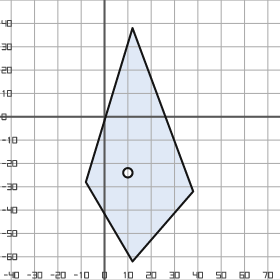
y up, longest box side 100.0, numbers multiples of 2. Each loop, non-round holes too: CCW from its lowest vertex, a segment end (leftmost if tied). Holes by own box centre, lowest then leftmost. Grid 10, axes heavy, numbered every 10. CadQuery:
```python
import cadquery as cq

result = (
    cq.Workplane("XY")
    .moveTo(12.0, -62.0)
    .lineTo(38.0, -32.0)
    .lineTo(12.0, 38.0)
    .lineTo(-8.0, -28.0)
    .close()
    .moveTo(10.0, -24.0)
    .circle(2.0)
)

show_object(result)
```